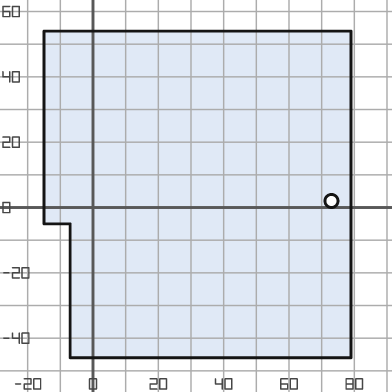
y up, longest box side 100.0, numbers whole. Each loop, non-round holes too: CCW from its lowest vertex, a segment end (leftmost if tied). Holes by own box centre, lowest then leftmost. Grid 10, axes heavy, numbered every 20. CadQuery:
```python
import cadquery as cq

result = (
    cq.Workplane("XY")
    .moveTo(-7.0, -46.0)
    .lineTo(79.0, -46.0)
    .lineTo(79.0, 54.0)
    .lineTo(-15.0, 54.0)
    .lineTo(-15.0, -5.0)
    .lineTo(-7.0, -5.0)
    .close()
    .moveTo(73.0, 2.0)
    .circle(2.0)
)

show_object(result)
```